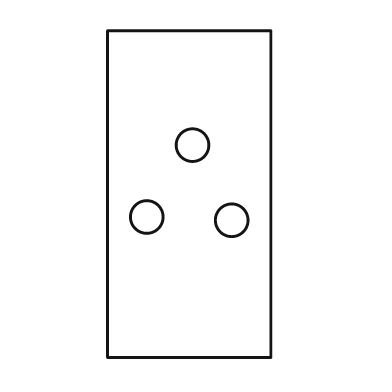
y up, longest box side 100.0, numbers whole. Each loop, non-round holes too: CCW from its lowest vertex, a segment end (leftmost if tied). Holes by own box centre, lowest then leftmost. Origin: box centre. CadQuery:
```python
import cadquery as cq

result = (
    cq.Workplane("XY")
    .moveTo(-25.0, -50.0)
    .lineTo(25.0, -50.0)
    .lineTo(25.0, 50.0)
    .lineTo(-25.0, 50.0)
    .close()
    .moveTo(13.0, -8.0)
    .circle(5.0)
    .moveTo(-13.0, -7.0)
    .circle(5.0)
    .moveTo(1.0, 15.0)
    .circle(5.0)
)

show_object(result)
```